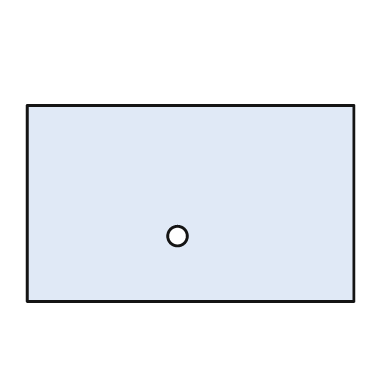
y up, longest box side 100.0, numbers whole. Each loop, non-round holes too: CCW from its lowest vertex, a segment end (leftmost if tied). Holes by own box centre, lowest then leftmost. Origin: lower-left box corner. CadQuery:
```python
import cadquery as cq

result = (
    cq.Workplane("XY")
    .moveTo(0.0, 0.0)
    .lineTo(100.0, 0.0)
    .lineTo(100.0, 60.0)
    .lineTo(0.0, 60.0)
    .close()
    .moveTo(46.0, 20.0)
    .circle(3.0)
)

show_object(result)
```